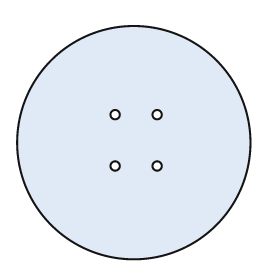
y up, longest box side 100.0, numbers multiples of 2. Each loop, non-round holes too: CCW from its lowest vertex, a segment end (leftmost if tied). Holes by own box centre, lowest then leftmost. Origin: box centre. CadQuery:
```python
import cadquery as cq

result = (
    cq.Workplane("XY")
    .moveTo(0.0, 0.0)
    .circle(50.0)
    .moveTo(-8.0, -10.0)
    .circle(2.0)
    .moveTo(10.0, -10.0)
    .circle(2.0)
    .moveTo(-8.0, 12.0)
    .circle(2.0)
    .moveTo(10.0, 12.0)
    .circle(2.0)
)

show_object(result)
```